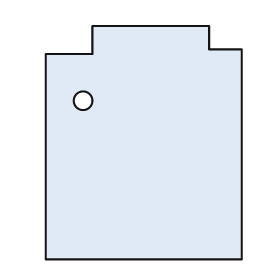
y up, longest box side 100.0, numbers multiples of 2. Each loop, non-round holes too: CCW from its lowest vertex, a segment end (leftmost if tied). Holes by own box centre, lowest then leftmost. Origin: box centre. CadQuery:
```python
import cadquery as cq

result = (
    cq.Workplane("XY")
    .moveTo(-42.0, -50.0)
    .lineTo(42.0, -50.0)
    .lineTo(42.0, 40.0)
    .lineTo(28.0, 40.0)
    .lineTo(28.0, 50.0)
    .lineTo(-22.0, 50.0)
    .lineTo(-22.0, 38.0)
    .lineTo(-42.0, 38.0)
    .close()
    .moveTo(-26.0, 18.0)
    .circle(4.0)
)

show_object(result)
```